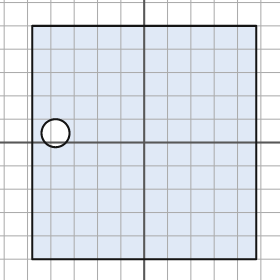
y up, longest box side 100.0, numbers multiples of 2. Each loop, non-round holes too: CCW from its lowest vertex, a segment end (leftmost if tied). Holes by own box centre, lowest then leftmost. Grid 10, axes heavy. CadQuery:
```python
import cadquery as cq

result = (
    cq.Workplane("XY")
    .moveTo(-48.0, -50.0)
    .lineTo(48.0, -50.0)
    .lineTo(48.0, 50.0)
    .lineTo(-48.0, 50.0)
    .close()
    .moveTo(-38.0, 4.0)
    .circle(6.0)
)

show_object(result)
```